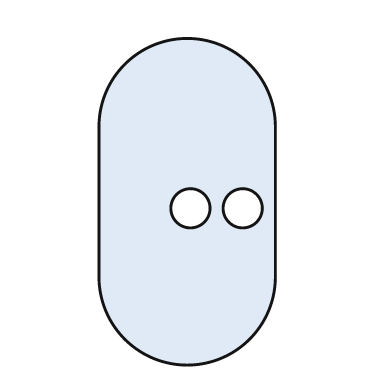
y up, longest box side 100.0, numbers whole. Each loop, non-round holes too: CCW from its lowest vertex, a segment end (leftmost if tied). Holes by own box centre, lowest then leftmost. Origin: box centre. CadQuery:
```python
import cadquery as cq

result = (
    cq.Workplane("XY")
    .moveTo(-27.0, -23.0)
    .threePointArc((0.0, -50.0), (27.0, -23.0))
    .lineTo(27.0, 23.0)
    .threePointArc((0.0, 50.0), (-27.0, 23.0))
    .close()
    .moveTo(1.0, -2.0)
    .circle(6.0)
    .moveTo(17.0, -2.0)
    .circle(6.0)
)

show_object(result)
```